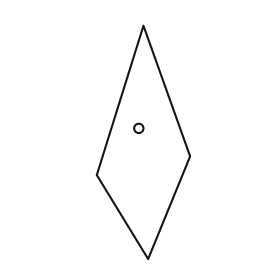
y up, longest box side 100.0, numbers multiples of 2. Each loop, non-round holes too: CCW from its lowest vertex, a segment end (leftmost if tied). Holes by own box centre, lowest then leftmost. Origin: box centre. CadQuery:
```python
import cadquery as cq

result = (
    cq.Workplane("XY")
    .moveTo(2.0, -50.0)
    .lineTo(20.0, -6.0)
    .lineTo(0.0, 50.0)
    .lineTo(-20.0, -14.0)
    .close()
    .moveTo(-2.0, 6.0)
    .circle(2.0)
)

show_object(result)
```